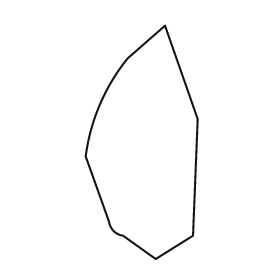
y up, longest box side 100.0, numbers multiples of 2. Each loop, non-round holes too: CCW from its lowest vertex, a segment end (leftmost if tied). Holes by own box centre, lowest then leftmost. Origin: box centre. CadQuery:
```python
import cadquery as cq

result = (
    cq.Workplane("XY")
    .moveTo(6.0, -50.0)
    .lineTo(22.0, -40.0)
    .lineTo(24.0, 10.0)
    .lineTo(10.0, 50.0)
    .lineTo(-6.0, 36.0)
    .threePointArc((-18.0, 16.0), (-24.0, -6.0))
    .lineTo(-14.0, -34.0)
    .threePointArc((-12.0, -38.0), (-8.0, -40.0))
    .close()
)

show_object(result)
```